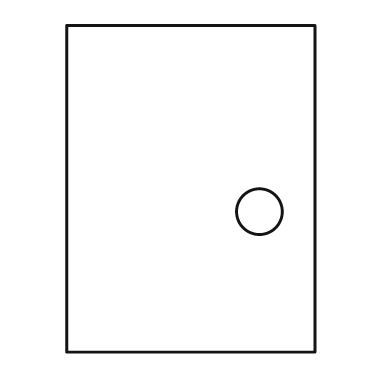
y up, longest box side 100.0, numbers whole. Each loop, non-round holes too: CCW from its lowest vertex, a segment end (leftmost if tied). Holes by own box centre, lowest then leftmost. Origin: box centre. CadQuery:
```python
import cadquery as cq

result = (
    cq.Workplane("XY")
    .moveTo(-38.0, -50.0)
    .lineTo(38.0, -50.0)
    .lineTo(38.0, 50.0)
    .lineTo(-38.0, 50.0)
    .close()
    .moveTo(21.0, -7.0)
    .circle(7.0)
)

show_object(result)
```